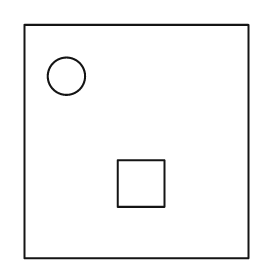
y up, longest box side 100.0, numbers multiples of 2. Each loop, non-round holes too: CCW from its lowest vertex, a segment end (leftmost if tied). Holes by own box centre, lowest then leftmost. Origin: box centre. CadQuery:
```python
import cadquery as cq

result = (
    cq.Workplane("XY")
    .moveTo(-48.0, -50.0)
    .lineTo(48.0, -50.0)
    .lineTo(48.0, 50.0)
    .lineTo(-48.0, 50.0)
    .close()
    .moveTo(-8.0, -28.0)
    .lineTo(12.0, -28.0)
    .lineTo(12.0, -8.0)
    .lineTo(-8.0, -8.0)
    .close()
    .moveTo(-30.0, 28.0)
    .circle(8.0)
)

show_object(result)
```